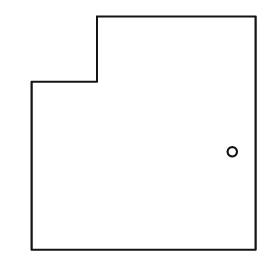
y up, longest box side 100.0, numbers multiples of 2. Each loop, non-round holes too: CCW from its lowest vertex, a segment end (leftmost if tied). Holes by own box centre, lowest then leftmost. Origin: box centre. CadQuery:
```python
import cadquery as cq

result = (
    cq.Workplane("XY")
    .moveTo(-48.0, -50.0)
    .lineTo(48.0, -50.0)
    .lineTo(48.0, 50.0)
    .lineTo(-20.0, 50.0)
    .lineTo(-20.0, 22.0)
    .lineTo(-48.0, 22.0)
    .close()
    .moveTo(38.0, -8.0)
    .circle(2.0)
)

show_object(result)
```